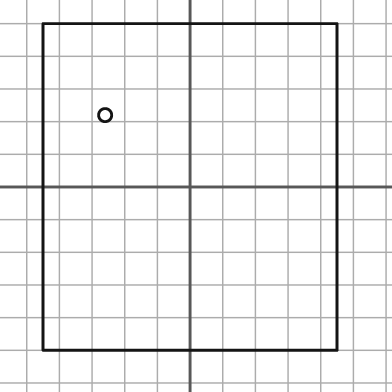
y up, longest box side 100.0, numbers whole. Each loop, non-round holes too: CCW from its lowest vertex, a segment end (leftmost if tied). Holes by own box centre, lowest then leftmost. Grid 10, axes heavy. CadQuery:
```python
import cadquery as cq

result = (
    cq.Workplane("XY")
    .moveTo(-45.0, -50.0)
    .lineTo(45.0, -50.0)
    .lineTo(45.0, 50.0)
    .lineTo(-45.0, 50.0)
    .close()
    .moveTo(-26.0, 22.0)
    .circle(2.0)
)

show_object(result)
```